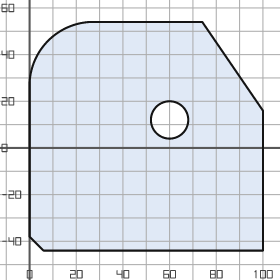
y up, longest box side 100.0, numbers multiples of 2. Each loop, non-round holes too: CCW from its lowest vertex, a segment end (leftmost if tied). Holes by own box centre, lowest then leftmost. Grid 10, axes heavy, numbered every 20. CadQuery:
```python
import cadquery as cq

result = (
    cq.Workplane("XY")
    .moveTo(6.0, -44.0)
    .lineTo(100.0, -44.0)
    .lineTo(100.0, 16.0)
    .lineTo(74.0, 54.0)
    .lineTo(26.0, 54.0)
    .threePointArc((8.0, 46.0), (0.0, 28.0))
    .lineTo(0.0, -38.0)
    .close()
    .moveTo(60.0, 12.0)
    .circle(8.0)
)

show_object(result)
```